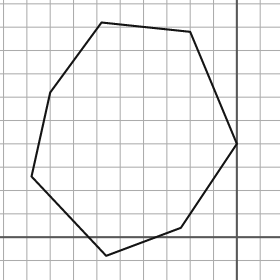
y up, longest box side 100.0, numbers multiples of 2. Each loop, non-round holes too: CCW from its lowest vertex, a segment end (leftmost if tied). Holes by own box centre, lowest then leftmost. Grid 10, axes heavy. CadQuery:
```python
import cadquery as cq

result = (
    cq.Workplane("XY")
    .moveTo(-56.0, -8.0)
    .lineTo(-24.0, 4.0)
    .lineTo(0.0, 40.0)
    .lineTo(-20.0, 88.0)
    .lineTo(-58.0, 92.0)
    .lineTo(-80.0, 62.0)
    .lineTo(-88.0, 26.0)
    .close()
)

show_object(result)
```